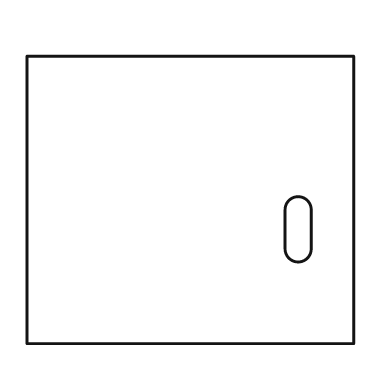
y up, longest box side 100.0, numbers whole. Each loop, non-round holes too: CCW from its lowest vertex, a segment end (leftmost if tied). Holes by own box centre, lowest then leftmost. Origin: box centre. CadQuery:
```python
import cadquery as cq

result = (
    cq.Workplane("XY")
    .moveTo(-50.0, -44.0)
    .lineTo(50.0, -44.0)
    .lineTo(50.0, 44.0)
    .lineTo(-50.0, 44.0)
    .close()
    .moveTo(29.0, -15.0)
    .threePointArc((33.0, -19.0), (37.0, -15.0))
    .lineTo(37.0, -3.0)
    .threePointArc((33.0, 1.0), (29.0, -3.0))
    .close()
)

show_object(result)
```